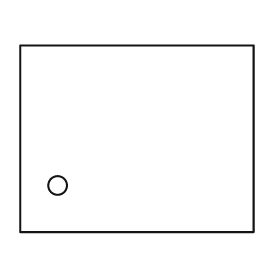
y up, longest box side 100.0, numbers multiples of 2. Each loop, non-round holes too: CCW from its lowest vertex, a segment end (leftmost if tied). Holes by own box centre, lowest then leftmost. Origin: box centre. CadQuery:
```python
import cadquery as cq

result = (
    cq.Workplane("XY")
    .moveTo(-50.0, -40.0)
    .lineTo(50.0, -40.0)
    .lineTo(50.0, 40.0)
    .lineTo(-50.0, 40.0)
    .close()
    .moveTo(-34.0, -20.0)
    .circle(4.0)
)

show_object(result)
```